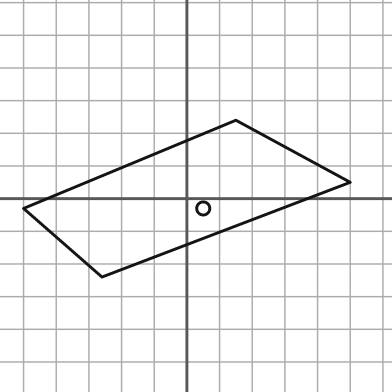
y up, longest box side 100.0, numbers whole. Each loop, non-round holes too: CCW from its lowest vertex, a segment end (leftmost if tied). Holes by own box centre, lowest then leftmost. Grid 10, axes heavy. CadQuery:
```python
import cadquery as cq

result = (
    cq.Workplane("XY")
    .moveTo(-26.0, -24.0)
    .lineTo(50.0, 5.0)
    .lineTo(15.0, 24.0)
    .lineTo(-50.0, -3.0)
    .close()
    .moveTo(5.0, -3.0)
    .circle(2.0)
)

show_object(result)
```